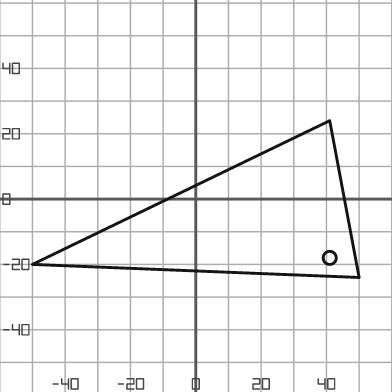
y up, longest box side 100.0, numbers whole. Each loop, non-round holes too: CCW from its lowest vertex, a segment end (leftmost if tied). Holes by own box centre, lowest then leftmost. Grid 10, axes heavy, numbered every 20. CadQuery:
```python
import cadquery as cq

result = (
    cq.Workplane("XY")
    .moveTo(50.0, -24.0)
    .lineTo(41.0, 24.0)
    .lineTo(-50.0, -20.0)
    .close()
    .moveTo(41.0, -18.0)
    .circle(2.0)
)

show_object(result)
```